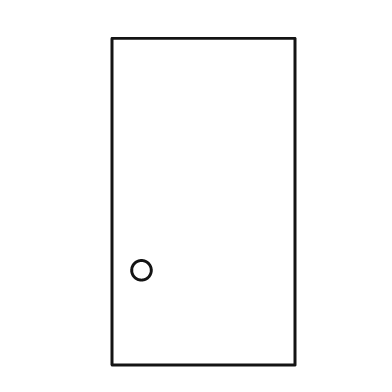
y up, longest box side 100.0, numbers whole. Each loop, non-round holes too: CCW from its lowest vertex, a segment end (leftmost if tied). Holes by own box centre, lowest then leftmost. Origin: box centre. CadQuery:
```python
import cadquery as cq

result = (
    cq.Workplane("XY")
    .moveTo(-28.0, -50.0)
    .lineTo(28.0, -50.0)
    .lineTo(28.0, 50.0)
    .lineTo(-28.0, 50.0)
    .close()
    .moveTo(-19.0, -21.0)
    .circle(3.0)
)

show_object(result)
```